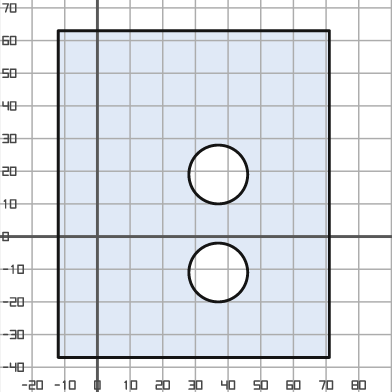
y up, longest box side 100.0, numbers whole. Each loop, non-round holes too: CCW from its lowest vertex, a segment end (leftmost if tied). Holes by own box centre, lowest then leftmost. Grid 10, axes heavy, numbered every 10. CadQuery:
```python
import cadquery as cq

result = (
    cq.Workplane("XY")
    .moveTo(-12.0, -37.0)
    .lineTo(71.0, -37.0)
    .lineTo(71.0, 63.0)
    .lineTo(-12.0, 63.0)
    .close()
    .moveTo(37.0, -11.0)
    .circle(9.0)
    .moveTo(37.0, 19.0)
    .circle(9.0)
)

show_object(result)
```